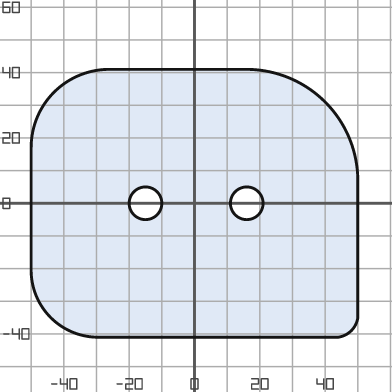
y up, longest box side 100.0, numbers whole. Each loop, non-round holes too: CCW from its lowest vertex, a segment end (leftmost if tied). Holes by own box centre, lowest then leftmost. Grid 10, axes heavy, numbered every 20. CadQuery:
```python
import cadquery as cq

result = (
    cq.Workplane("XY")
    .moveTo(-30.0, -41.0)
    .lineTo(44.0, -41.0)
    .threePointArc((48.0, -39.0), (50.0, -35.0))
    .lineTo(50.0, 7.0)
    .threePointArc((40.0, 31.0), (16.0, 41.0))
    .lineTo(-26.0, 41.0)
    .threePointArc((-43.0, 34.0), (-50.0, 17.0))
    .lineTo(-50.0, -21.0)
    .threePointArc((-44.0, -35.0), (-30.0, -41.0))
    .close()
    .moveTo(-15.0, 0.0)
    .circle(5.0)
    .moveTo(16.0, 0.0)
    .circle(5.0)
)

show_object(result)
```